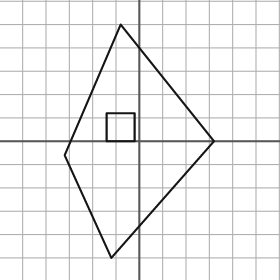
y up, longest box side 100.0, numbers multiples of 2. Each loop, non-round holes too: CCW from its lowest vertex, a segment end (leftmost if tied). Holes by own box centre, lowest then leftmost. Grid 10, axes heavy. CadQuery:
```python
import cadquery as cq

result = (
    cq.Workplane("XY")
    .moveTo(-12.0, -50.0)
    .lineTo(32.0, 0.0)
    .lineTo(-8.0, 50.0)
    .lineTo(-32.0, -6.0)
    .close()
    .moveTo(-14.0, 0.0)
    .lineTo(-2.0, 0.0)
    .lineTo(-2.0, 12.0)
    .lineTo(-14.0, 12.0)
    .close()
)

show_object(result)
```